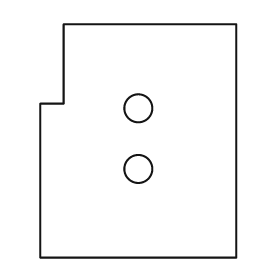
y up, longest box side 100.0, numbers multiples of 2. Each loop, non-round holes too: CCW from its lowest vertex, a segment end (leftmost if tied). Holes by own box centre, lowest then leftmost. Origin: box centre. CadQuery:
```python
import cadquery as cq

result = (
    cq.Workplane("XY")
    .moveTo(-42.0, -50.0)
    .lineTo(42.0, -50.0)
    .lineTo(42.0, 50.0)
    .lineTo(-32.0, 50.0)
    .lineTo(-32.0, 16.0)
    .lineTo(-42.0, 16.0)
    .close()
    .moveTo(0.0, -12.0)
    .circle(6.0)
    .moveTo(0.0, 14.0)
    .circle(6.0)
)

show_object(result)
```